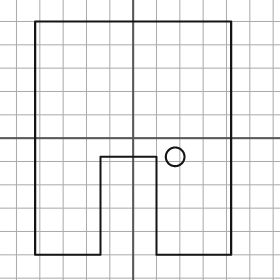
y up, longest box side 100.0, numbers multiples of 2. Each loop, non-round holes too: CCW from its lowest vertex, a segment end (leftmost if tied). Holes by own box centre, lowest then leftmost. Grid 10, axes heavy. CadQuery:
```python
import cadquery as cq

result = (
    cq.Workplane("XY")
    .moveTo(-42.0, -50.0)
    .lineTo(-14.0, -50.0)
    .lineTo(-14.0, -8.0)
    .lineTo(10.0, -8.0)
    .lineTo(10.0, -50.0)
    .lineTo(42.0, -50.0)
    .lineTo(42.0, 50.0)
    .lineTo(-42.0, 50.0)
    .close()
    .moveTo(18.0, -8.0)
    .circle(4.0)
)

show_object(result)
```